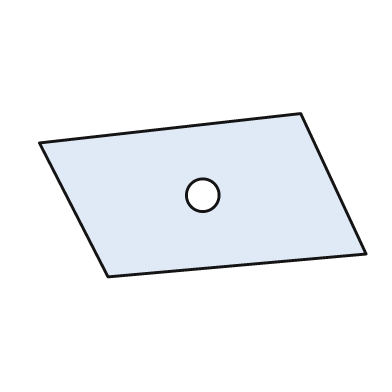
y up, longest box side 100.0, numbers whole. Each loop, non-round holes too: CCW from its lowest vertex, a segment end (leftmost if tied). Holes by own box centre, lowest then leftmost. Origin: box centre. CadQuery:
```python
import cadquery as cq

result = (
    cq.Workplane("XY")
    .moveTo(-29.0, -25.0)
    .lineTo(50.0, -18.0)
    .lineTo(30.0, 25.0)
    .lineTo(-50.0, 16.0)
    .close()
    .moveTo(0.0, 0.0)
    .circle(5.0)
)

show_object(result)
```